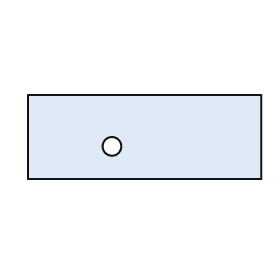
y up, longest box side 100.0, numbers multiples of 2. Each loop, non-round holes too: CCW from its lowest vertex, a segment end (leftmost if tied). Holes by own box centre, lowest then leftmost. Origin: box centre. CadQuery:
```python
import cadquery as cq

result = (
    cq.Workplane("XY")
    .moveTo(-50.0, -18.0)
    .lineTo(50.0, -18.0)
    .lineTo(50.0, 18.0)
    .lineTo(-50.0, 18.0)
    .close()
    .moveTo(-14.0, -4.0)
    .circle(4.0)
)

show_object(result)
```